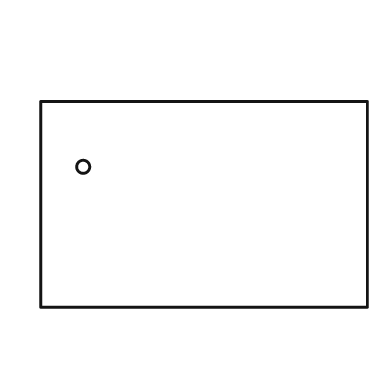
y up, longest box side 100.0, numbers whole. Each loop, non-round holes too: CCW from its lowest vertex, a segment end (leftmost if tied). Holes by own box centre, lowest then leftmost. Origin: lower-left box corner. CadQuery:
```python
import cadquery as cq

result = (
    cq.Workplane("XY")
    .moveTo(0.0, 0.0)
    .lineTo(100.0, 0.0)
    .lineTo(100.0, 63.0)
    .lineTo(0.0, 63.0)
    .close()
    .moveTo(13.0, 43.0)
    .circle(2.0)
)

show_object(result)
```